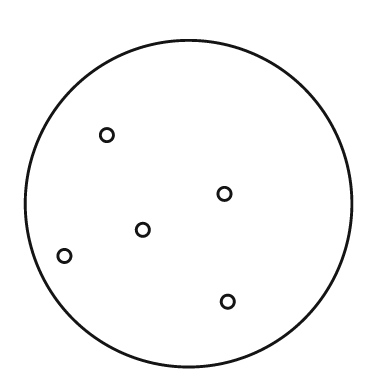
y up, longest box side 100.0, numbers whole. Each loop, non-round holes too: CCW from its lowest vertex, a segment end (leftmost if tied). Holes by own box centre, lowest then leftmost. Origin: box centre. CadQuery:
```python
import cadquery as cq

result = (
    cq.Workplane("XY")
    .moveTo(0.0, 0.0)
    .circle(50.0)
    .moveTo(12.0, -30.0)
    .circle(2.0)
    .moveTo(-38.0, -16.0)
    .circle(2.0)
    .moveTo(-14.0, -8.0)
    .circle(2.0)
    .moveTo(11.0, 3.0)
    .circle(2.0)
    .moveTo(-25.0, 21.0)
    .circle(2.0)
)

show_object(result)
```